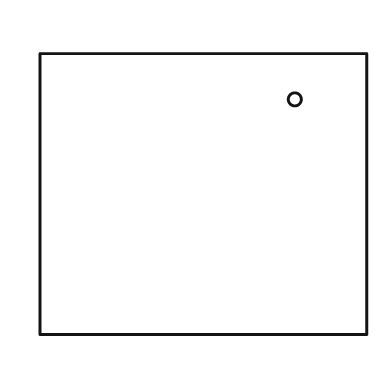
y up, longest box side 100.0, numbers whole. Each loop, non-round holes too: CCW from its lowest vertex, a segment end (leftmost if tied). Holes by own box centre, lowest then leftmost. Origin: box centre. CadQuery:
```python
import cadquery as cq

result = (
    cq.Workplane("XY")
    .moveTo(-50.0, -43.0)
    .lineTo(50.0, -43.0)
    .lineTo(50.0, 43.0)
    .lineTo(-50.0, 43.0)
    .close()
    .moveTo(28.0, 29.0)
    .circle(2.0)
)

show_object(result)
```